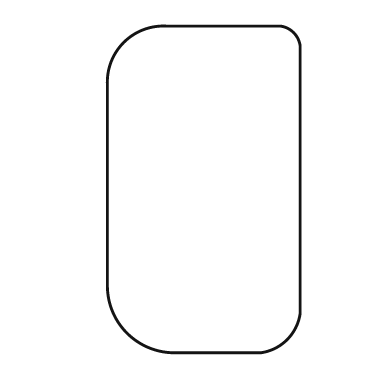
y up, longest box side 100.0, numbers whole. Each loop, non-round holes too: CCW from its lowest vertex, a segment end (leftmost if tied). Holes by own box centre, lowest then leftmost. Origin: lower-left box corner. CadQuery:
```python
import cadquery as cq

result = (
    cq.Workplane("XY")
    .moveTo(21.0, 0.0)
    .lineTo(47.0, 0.0)
    .threePointArc((55.0, 4.0), (59.0, 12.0))
    .lineTo(59.0, 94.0)
    .threePointArc((57.0, 98.0), (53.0, 100.0))
    .lineTo(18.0, 100.0)
    .threePointArc((5.0, 95.0), (0.0, 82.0))
    .lineTo(0.0, 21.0)
    .threePointArc((6.0, 6.0), (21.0, 0.0))
    .close()
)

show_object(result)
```